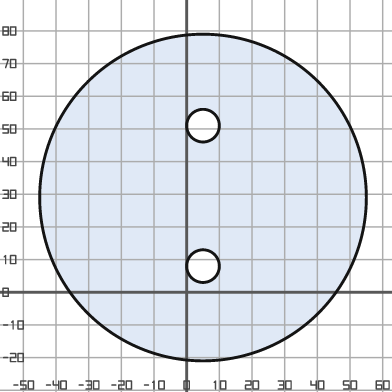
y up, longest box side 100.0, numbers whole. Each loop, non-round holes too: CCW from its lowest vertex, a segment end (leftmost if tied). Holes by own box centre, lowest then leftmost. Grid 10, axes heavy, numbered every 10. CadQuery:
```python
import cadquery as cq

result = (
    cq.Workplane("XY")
    .moveTo(5.0, 29.0)
    .circle(50.0)
    .moveTo(5.0, 8.0)
    .circle(5.0)
    .moveTo(5.0, 51.0)
    .circle(5.0)
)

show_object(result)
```